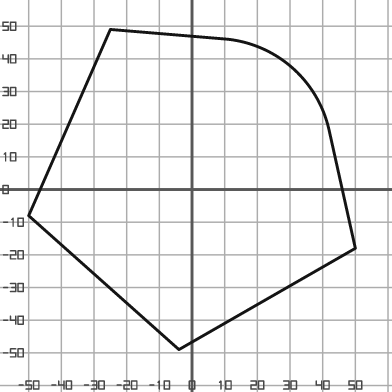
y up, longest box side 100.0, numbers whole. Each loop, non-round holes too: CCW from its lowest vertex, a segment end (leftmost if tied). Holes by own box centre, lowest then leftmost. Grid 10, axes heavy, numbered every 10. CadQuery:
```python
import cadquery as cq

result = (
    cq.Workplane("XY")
    .moveTo(-4.0, -49.0)
    .lineTo(50.0, -18.0)
    .lineTo(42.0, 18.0)
    .threePointArc((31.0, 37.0), (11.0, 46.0))
    .lineTo(-25.0, 49.0)
    .lineTo(-50.0, -8.0)
    .close()
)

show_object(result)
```